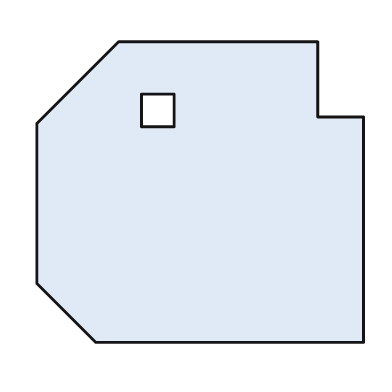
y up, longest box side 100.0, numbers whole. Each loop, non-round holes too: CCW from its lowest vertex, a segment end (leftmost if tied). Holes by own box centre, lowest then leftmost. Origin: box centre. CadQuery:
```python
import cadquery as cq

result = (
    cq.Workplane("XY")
    .moveTo(-32.0, -46.0)
    .lineTo(50.0, -46.0)
    .lineTo(50.0, 23.0)
    .lineTo(36.0, 23.0)
    .lineTo(36.0, 46.0)
    .lineTo(-25.0, 46.0)
    .lineTo(-50.0, 21.0)
    .lineTo(-50.0, -28.0)
    .close()
    .moveTo(-18.0, 20.0)
    .lineTo(-8.0, 20.0)
    .lineTo(-8.0, 30.0)
    .lineTo(-18.0, 30.0)
    .close()
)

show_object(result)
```